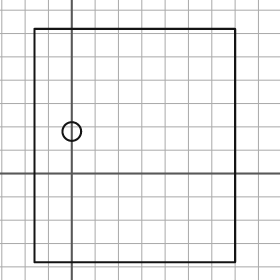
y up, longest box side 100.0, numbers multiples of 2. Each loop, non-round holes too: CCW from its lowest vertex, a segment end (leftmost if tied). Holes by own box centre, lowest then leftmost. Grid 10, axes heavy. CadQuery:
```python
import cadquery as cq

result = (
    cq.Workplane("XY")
    .moveTo(-16.0, -38.0)
    .lineTo(70.0, -38.0)
    .lineTo(70.0, 62.0)
    .lineTo(-16.0, 62.0)
    .close()
    .moveTo(0.0, 18.0)
    .circle(4.0)
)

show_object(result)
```